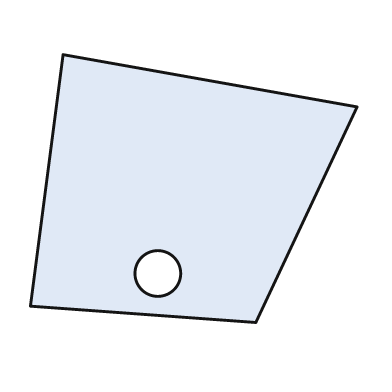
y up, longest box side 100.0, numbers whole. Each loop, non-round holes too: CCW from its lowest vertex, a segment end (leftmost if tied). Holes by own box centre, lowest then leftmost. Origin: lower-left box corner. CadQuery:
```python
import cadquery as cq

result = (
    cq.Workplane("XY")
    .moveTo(69.0, 0.0)
    .lineTo(100.0, 66.0)
    .lineTo(10.0, 82.0)
    .lineTo(0.0, 5.0)
    .close()
    .moveTo(39.0, 15.0)
    .circle(7.0)
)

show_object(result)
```